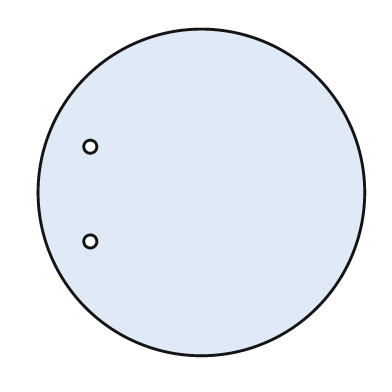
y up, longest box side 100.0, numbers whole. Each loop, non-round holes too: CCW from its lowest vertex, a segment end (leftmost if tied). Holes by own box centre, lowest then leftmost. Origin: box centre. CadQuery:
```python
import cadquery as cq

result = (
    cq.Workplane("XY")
    .moveTo(0.0, 0.0)
    .circle(50.0)
    .moveTo(-34.0, -15.0)
    .circle(2.0)
    .moveTo(-34.0, 14.0)
    .circle(2.0)
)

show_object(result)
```